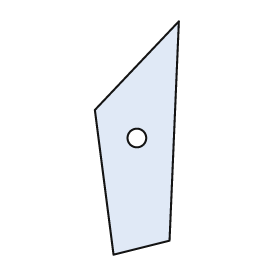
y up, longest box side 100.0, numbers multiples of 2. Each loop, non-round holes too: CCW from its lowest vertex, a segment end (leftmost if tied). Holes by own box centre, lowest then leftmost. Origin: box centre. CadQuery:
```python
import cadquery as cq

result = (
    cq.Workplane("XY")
    .moveTo(-10.0, -50.0)
    .lineTo(14.0, -44.0)
    .lineTo(18.0, 50.0)
    .lineTo(-18.0, 12.0)
    .close()
    .moveTo(0.0, 0.0)
    .circle(4.0)
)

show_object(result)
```